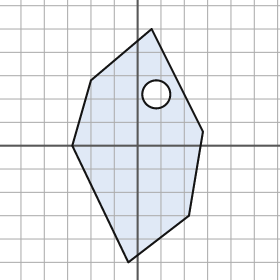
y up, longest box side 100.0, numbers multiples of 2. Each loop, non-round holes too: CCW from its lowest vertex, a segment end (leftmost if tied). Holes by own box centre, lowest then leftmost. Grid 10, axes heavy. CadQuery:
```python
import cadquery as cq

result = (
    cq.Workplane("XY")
    .moveTo(-4.0, -50.0)
    .lineTo(22.0, -30.0)
    .lineTo(28.0, 6.0)
    .lineTo(6.0, 50.0)
    .lineTo(-20.0, 28.0)
    .lineTo(-28.0, 0.0)
    .close()
    .moveTo(8.0, 22.0)
    .circle(6.0)
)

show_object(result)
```